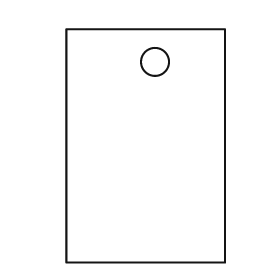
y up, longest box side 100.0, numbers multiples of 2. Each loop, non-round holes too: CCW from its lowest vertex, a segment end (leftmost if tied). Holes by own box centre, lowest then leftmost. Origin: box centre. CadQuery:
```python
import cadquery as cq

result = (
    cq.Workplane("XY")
    .moveTo(-34.0, -50.0)
    .lineTo(34.0, -50.0)
    .lineTo(34.0, 50.0)
    .lineTo(-34.0, 50.0)
    .close()
    .moveTo(4.0, 36.0)
    .circle(6.0)
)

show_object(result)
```